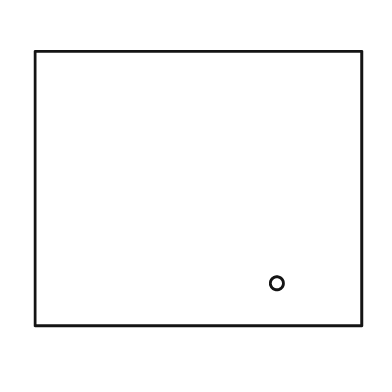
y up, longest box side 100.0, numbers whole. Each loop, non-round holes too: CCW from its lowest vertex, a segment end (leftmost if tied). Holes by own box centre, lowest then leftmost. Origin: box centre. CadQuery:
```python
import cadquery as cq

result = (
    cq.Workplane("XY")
    .moveTo(-50.0, -42.0)
    .lineTo(50.0, -42.0)
    .lineTo(50.0, 42.0)
    .lineTo(-50.0, 42.0)
    .close()
    .moveTo(24.0, -29.0)
    .circle(2.0)
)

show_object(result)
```